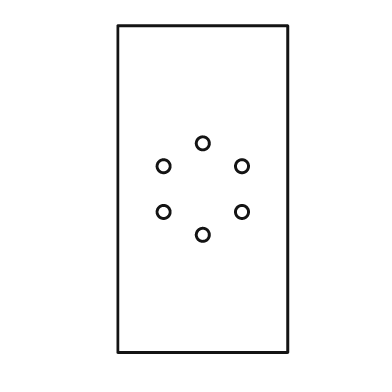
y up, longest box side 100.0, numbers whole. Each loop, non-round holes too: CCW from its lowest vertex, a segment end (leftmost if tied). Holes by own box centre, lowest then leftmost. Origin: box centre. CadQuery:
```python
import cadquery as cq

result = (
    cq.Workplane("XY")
    .moveTo(-26.0, -50.0)
    .lineTo(26.0, -50.0)
    .lineTo(26.0, 50.0)
    .lineTo(-26.0, 50.0)
    .close()
    .moveTo(0.0, -14.0)
    .circle(2.0)
    .moveTo(-12.0, -7.0)
    .circle(2.0)
    .moveTo(12.0, -7.0)
    .circle(2.0)
    .moveTo(-12.0, 7.0)
    .circle(2.0)
    .moveTo(12.0, 7.0)
    .circle(2.0)
    .moveTo(0.0, 14.0)
    .circle(2.0)
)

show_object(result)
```